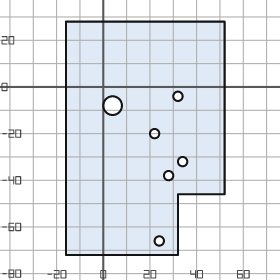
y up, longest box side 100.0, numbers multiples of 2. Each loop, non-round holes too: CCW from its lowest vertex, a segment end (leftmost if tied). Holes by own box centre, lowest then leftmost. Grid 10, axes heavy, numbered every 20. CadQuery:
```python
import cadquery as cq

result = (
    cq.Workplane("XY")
    .moveTo(-16.0, -72.0)
    .lineTo(32.0, -72.0)
    .lineTo(32.0, -46.0)
    .lineTo(52.0, -46.0)
    .lineTo(52.0, 28.0)
    .lineTo(-16.0, 28.0)
    .close()
    .moveTo(24.0, -66.0)
    .circle(2.0)
    .moveTo(28.0, -38.0)
    .circle(2.0)
    .moveTo(34.0, -32.0)
    .circle(2.0)
    .moveTo(22.0, -20.0)
    .circle(2.0)
    .moveTo(4.0, -8.0)
    .circle(4.0)
    .moveTo(32.0, -4.0)
    .circle(2.0)
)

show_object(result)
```